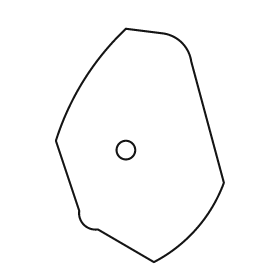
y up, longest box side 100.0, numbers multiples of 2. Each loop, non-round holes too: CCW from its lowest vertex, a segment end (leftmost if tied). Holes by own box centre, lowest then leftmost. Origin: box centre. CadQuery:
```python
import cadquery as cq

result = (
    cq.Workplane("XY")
    .moveTo(6.0, -50.0)
    .threePointArc((24.0, -36.0), (36.0, -16.0))
    .lineTo(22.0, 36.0)
    .threePointArc((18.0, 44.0), (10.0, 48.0))
    .lineTo(-6.0, 50.0)
    .threePointArc((-24.0, 28.0), (-36.0, 2.0))
    .lineTo(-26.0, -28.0)
    .threePointArc((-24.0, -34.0), (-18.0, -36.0))
    .close()
    .moveTo(-6.0, -2.0)
    .circle(4.0)
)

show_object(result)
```